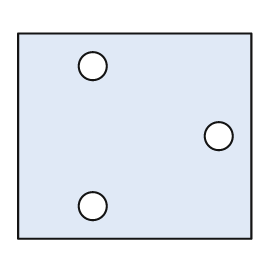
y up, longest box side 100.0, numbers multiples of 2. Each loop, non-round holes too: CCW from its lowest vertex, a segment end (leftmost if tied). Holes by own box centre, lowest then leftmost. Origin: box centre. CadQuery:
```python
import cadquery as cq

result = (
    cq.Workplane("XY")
    .moveTo(-50.0, -44.0)
    .lineTo(50.0, -44.0)
    .lineTo(50.0, 44.0)
    .lineTo(-50.0, 44.0)
    .close()
    .moveTo(-18.0, -30.0)
    .circle(6.0)
    .moveTo(36.0, 0.0)
    .circle(6.0)
    .moveTo(-18.0, 30.0)
    .circle(6.0)
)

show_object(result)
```